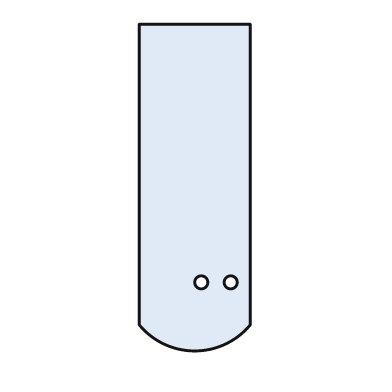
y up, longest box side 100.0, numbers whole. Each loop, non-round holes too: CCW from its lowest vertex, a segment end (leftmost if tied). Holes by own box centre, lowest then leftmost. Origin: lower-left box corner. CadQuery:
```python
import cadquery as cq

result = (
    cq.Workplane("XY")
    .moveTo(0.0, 8.0)
    .threePointArc((17.0, 0.0), (34.0, 8.0))
    .lineTo(34.0, 100.0)
    .lineTo(0.0, 100.0)
    .close()
    .moveTo(19.0, 21.0)
    .circle(2.0)
    .moveTo(28.0, 21.0)
    .circle(2.0)
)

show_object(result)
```